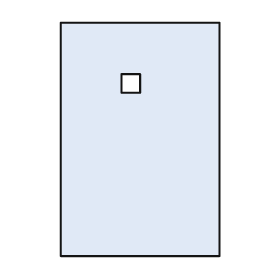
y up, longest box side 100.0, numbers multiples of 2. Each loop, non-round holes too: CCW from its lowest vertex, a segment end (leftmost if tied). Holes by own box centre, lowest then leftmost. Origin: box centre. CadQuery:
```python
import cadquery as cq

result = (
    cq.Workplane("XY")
    .moveTo(-34.0, -50.0)
    .lineTo(34.0, -50.0)
    .lineTo(34.0, 50.0)
    .lineTo(-34.0, 50.0)
    .close()
    .moveTo(-8.0, 20.0)
    .lineTo(0.0, 20.0)
    .lineTo(0.0, 28.0)
    .lineTo(-8.0, 28.0)
    .close()
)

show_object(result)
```